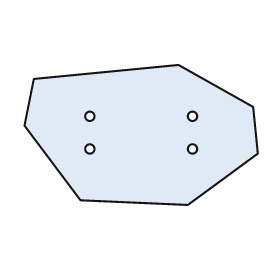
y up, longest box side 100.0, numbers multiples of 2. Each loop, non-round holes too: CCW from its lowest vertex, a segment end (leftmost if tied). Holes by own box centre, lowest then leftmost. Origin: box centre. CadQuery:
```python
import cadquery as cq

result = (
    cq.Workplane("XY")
    .moveTo(20.0, -30.0)
    .lineTo(50.0, -8.0)
    .lineTo(48.0, 12.0)
    .lineTo(16.0, 30.0)
    .lineTo(-46.0, 24.0)
    .lineTo(-50.0, 4.0)
    .lineTo(-26.0, -28.0)
    .close()
    .moveTo(-22.0, -6.0)
    .circle(2.0)
    .moveTo(22.0, -6.0)
    .circle(2.0)
    .moveTo(-22.0, 8.0)
    .circle(2.0)
    .moveTo(22.0, 8.0)
    .circle(2.0)
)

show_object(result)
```